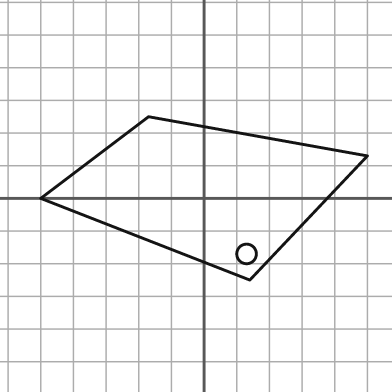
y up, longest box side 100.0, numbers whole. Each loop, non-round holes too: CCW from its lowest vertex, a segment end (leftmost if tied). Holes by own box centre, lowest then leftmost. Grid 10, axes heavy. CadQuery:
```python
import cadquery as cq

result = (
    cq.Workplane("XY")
    .moveTo(14.0, -25.0)
    .lineTo(50.0, 13.0)
    .lineTo(-17.0, 25.0)
    .lineTo(-50.0, 0.0)
    .close()
    .moveTo(13.0, -17.0)
    .circle(3.0)
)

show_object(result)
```